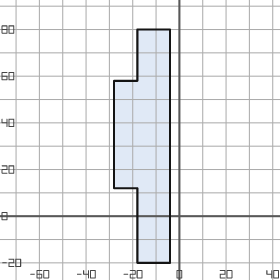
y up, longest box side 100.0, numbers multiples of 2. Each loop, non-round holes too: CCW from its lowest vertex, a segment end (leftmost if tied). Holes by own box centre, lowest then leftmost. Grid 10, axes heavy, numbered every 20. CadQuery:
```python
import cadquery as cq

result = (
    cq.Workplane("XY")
    .moveTo(-18.0, -20.0)
    .lineTo(-4.0, -20.0)
    .lineTo(-4.0, 80.0)
    .lineTo(-18.0, 80.0)
    .lineTo(-18.0, 58.0)
    .lineTo(-28.0, 58.0)
    .lineTo(-28.0, 12.0)
    .lineTo(-18.0, 12.0)
    .close()
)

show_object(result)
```